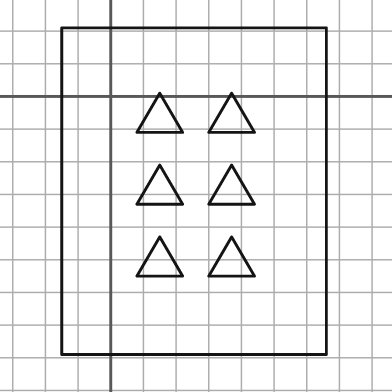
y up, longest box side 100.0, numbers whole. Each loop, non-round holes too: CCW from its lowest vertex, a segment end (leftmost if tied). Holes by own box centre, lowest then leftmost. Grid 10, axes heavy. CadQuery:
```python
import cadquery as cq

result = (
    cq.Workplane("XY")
    .moveTo(-15.0, -79.0)
    .lineTo(66.0, -79.0)
    .lineTo(66.0, 21.0)
    .lineTo(-15.0, 21.0)
    .close()
    .moveTo(8.0, -55.0)
    .lineTo(22.0, -55.0)
    .lineTo(15.0, -43.0)
    .close()
    .moveTo(30.0, -55.0)
    .lineTo(44.0, -55.0)
    .lineTo(37.0, -43.0)
    .close()
    .moveTo(8.0, -33.0)
    .lineTo(22.0, -33.0)
    .lineTo(15.0, -21.0)
    .close()
    .moveTo(30.0, -33.0)
    .lineTo(44.0, -33.0)
    .lineTo(37.0, -21.0)
    .close()
    .moveTo(8.0, -11.0)
    .lineTo(22.0, -11.0)
    .lineTo(15.0, 1.0)
    .close()
    .moveTo(30.0, -11.0)
    .lineTo(44.0, -11.0)
    .lineTo(37.0, 1.0)
    .close()
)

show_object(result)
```